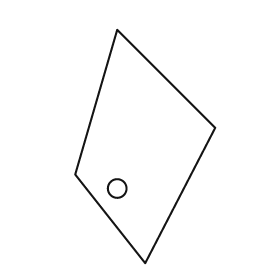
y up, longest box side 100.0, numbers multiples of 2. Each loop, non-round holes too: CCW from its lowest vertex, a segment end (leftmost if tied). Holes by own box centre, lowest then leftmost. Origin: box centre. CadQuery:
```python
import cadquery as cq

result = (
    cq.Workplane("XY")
    .moveTo(0.0, -50.0)
    .lineTo(30.0, 8.0)
    .lineTo(-12.0, 50.0)
    .lineTo(-30.0, -12.0)
    .close()
    .moveTo(-12.0, -18.0)
    .circle(4.0)
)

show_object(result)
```